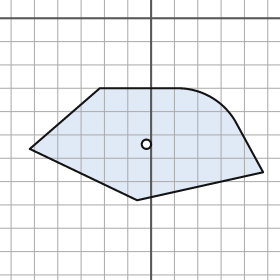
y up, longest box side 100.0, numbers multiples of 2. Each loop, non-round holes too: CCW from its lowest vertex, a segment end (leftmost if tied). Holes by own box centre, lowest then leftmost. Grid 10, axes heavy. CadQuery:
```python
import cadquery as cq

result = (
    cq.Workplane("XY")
    .moveTo(-6.0, -78.0)
    .lineTo(48.0, -66.0)
    .lineTo(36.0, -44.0)
    .threePointArc((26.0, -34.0), (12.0, -30.0))
    .lineTo(-22.0, -30.0)
    .lineTo(-52.0, -56.0)
    .close()
    .moveTo(-2.0, -54.0)
    .circle(2.0)
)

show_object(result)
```